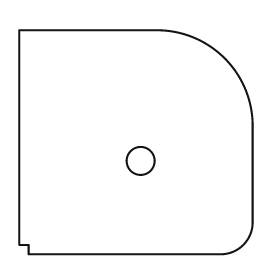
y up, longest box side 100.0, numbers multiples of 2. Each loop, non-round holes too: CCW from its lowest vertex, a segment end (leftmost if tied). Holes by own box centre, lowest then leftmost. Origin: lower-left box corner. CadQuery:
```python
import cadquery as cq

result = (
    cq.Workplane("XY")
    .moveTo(4.0, 0.0)
    .lineTo(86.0, 0.0)
    .threePointArc((96.0, 4.0), (100.0, 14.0))
    .lineTo(100.0, 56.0)
    .threePointArc((88.0, 84.0), (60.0, 96.0))
    .lineTo(0.0, 96.0)
    .lineTo(0.0, 4.0)
    .lineTo(4.0, 4.0)
    .close()
    .moveTo(52.0, 40.0)
    .circle(6.0)
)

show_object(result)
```